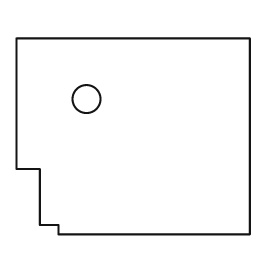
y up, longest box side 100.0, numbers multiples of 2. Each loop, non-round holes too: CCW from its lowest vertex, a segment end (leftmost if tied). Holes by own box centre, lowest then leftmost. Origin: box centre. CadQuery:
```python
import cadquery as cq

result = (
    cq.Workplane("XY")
    .moveTo(-32.0, -42.0)
    .lineTo(50.0, -42.0)
    .lineTo(50.0, 42.0)
    .lineTo(-50.0, 42.0)
    .lineTo(-50.0, -14.0)
    .lineTo(-40.0, -14.0)
    .lineTo(-40.0, -38.0)
    .lineTo(-32.0, -38.0)
    .close()
    .moveTo(-20.0, 16.0)
    .circle(6.0)
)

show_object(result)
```